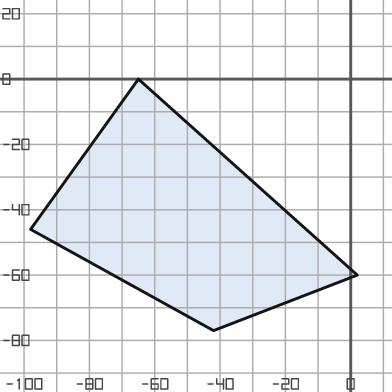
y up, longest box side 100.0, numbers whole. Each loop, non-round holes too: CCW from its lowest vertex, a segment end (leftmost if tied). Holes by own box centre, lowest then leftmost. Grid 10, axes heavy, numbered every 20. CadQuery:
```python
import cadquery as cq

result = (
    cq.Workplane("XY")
    .moveTo(-42.0, -77.0)
    .lineTo(2.0, -60.0)
    .lineTo(-65.0, 0.0)
    .lineTo(-98.0, -46.0)
    .close()
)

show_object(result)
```